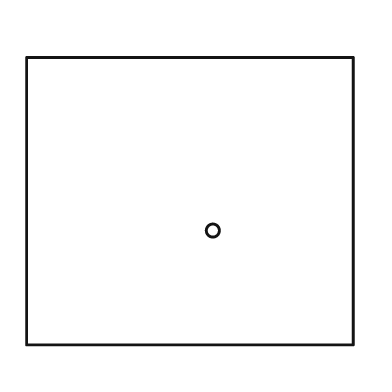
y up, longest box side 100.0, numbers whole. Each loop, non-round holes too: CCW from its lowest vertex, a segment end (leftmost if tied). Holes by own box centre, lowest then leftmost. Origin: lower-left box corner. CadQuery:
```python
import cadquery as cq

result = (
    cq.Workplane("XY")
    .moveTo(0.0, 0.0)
    .lineTo(100.0, 0.0)
    .lineTo(100.0, 88.0)
    .lineTo(0.0, 88.0)
    .close()
    .moveTo(57.0, 35.0)
    .circle(2.0)
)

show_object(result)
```